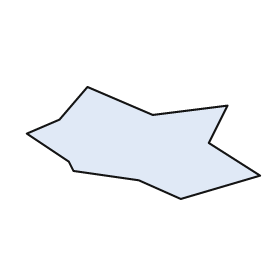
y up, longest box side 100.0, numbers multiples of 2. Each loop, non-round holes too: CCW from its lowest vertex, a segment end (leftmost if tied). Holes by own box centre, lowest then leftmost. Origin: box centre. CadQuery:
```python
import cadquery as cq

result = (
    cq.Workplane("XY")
    .moveTo(16.0, -24.0)
    .lineTo(50.0, -14.0)
    .lineTo(28.0, 0.0)
    .lineTo(36.0, 16.0)
    .lineTo(4.0, 12.0)
    .lineTo(-24.0, 24.0)
    .lineTo(-36.0, 10.0)
    .lineTo(-50.0, 4.0)
    .lineTo(-32.0, -8.0)
    .lineTo(-30.0, -12.0)
    .lineTo(-2.0, -16.0)
    .close()
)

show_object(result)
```